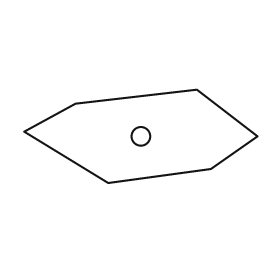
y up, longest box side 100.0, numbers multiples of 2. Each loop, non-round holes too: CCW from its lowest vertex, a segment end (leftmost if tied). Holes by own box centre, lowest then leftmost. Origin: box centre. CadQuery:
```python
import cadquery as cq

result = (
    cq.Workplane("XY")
    .moveTo(-14.0, -20.0)
    .lineTo(30.0, -14.0)
    .lineTo(50.0, 0.0)
    .lineTo(24.0, 20.0)
    .lineTo(-28.0, 14.0)
    .lineTo(-50.0, 2.0)
    .close()
    .moveTo(0.0, 0.0)
    .circle(4.0)
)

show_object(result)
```